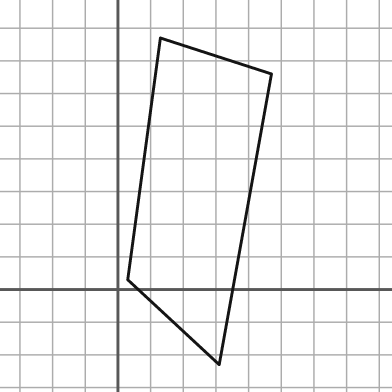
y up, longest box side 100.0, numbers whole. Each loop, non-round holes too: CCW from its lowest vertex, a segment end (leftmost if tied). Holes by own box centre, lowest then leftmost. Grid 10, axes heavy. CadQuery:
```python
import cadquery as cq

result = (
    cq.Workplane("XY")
    .moveTo(31.0, -23.0)
    .lineTo(47.0, 66.0)
    .lineTo(13.0, 77.0)
    .lineTo(3.0, 3.0)
    .close()
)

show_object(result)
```